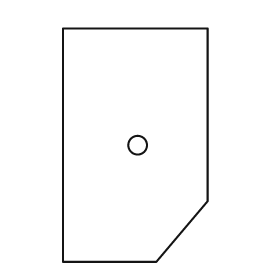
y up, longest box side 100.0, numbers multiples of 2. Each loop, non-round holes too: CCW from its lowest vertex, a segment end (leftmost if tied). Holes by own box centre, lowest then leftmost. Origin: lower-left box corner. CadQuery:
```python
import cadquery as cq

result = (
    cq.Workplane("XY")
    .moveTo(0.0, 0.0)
    .lineTo(40.0, 0.0)
    .lineTo(62.0, 26.0)
    .lineTo(62.0, 100.0)
    .lineTo(0.0, 100.0)
    .close()
    .moveTo(32.0, 50.0)
    .circle(4.0)
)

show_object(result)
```